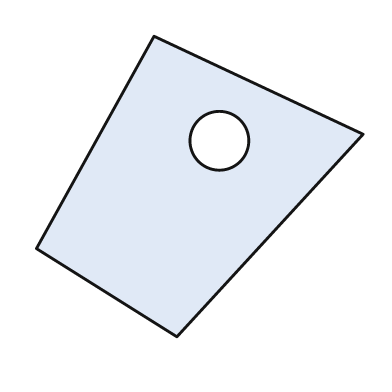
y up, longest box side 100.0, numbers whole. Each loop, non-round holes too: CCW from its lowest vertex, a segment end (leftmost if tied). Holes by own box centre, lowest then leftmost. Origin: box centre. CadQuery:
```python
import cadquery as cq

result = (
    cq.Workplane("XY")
    .moveTo(-7.0, -46.0)
    .lineTo(50.0, 16.0)
    .lineTo(-14.0, 46.0)
    .lineTo(-50.0, -19.0)
    .close()
    .moveTo(6.0, 14.0)
    .circle(9.0)
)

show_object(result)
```